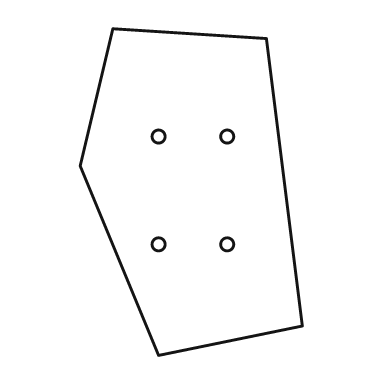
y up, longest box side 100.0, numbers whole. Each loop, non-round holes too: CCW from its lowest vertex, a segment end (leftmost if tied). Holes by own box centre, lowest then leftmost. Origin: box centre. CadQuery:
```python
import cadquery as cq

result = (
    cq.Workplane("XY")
    .moveTo(-10.0, -50.0)
    .lineTo(34.0, -41.0)
    .lineTo(23.0, 47.0)
    .lineTo(-24.0, 50.0)
    .lineTo(-34.0, 8.0)
    .close()
    .moveTo(-10.0, -16.0)
    .circle(2.0)
    .moveTo(11.0, -16.0)
    .circle(2.0)
    .moveTo(-10.0, 17.0)
    .circle(2.0)
    .moveTo(11.0, 17.0)
    .circle(2.0)
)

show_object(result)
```